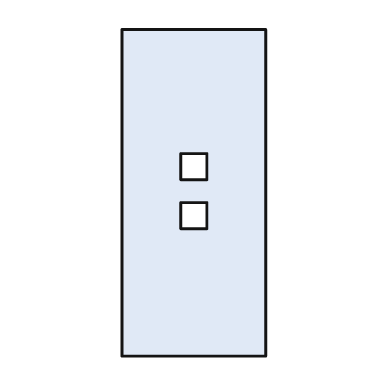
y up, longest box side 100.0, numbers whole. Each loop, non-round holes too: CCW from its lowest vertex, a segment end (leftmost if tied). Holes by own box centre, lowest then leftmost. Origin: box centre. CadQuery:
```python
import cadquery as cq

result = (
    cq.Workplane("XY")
    .moveTo(-22.0, -50.0)
    .lineTo(22.0, -50.0)
    .lineTo(22.0, 50.0)
    .lineTo(-22.0, 50.0)
    .close()
    .moveTo(-4.0, -11.0)
    .lineTo(4.0, -11.0)
    .lineTo(4.0, -3.0)
    .lineTo(-4.0, -3.0)
    .close()
    .moveTo(-4.0, 4.0)
    .lineTo(4.0, 4.0)
    .lineTo(4.0, 12.0)
    .lineTo(-4.0, 12.0)
    .close()
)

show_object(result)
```